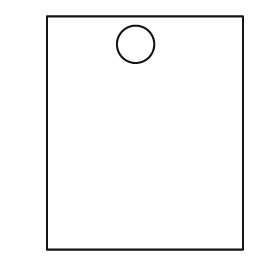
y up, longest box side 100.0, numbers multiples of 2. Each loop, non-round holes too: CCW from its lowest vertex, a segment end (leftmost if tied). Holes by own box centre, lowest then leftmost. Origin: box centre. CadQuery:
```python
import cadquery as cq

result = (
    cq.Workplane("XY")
    .moveTo(-42.0, -50.0)
    .lineTo(42.0, -50.0)
    .lineTo(42.0, 50.0)
    .lineTo(-42.0, 50.0)
    .close()
    .moveTo(-4.0, 38.0)
    .circle(8.0)
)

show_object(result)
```